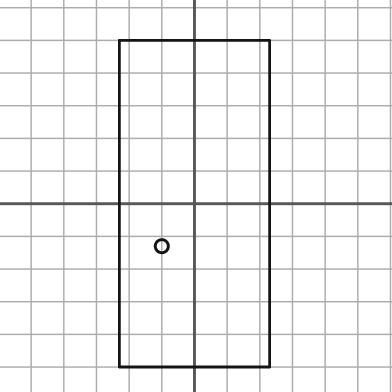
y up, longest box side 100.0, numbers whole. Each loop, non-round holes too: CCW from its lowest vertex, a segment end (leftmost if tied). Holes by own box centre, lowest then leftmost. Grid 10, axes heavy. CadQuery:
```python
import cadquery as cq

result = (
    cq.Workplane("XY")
    .moveTo(-23.0, -50.0)
    .lineTo(23.0, -50.0)
    .lineTo(23.0, 50.0)
    .lineTo(-23.0, 50.0)
    .close()
    .moveTo(-10.0, -13.0)
    .circle(2.0)
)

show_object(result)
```